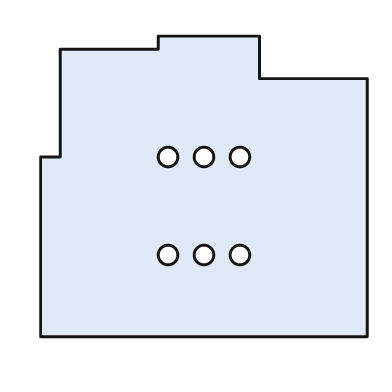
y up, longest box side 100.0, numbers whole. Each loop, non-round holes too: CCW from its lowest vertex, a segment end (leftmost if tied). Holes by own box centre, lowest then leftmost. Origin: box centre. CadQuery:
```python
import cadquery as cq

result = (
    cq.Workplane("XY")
    .moveTo(-50.0, -46.0)
    .lineTo(50.0, -46.0)
    .lineTo(50.0, 33.0)
    .lineTo(17.0, 33.0)
    .lineTo(17.0, 46.0)
    .lineTo(-14.0, 46.0)
    .lineTo(-14.0, 42.0)
    .lineTo(-44.0, 42.0)
    .lineTo(-44.0, 9.0)
    .lineTo(-50.0, 9.0)
    .close()
    .moveTo(-11.0, -21.0)
    .circle(3.0)
    .moveTo(0.0, -21.0)
    .circle(3.0)
    .moveTo(11.0, -21.0)
    .circle(3.0)
    .moveTo(-11.0, 9.0)
    .circle(3.0)
    .moveTo(0.0, 9.0)
    .circle(3.0)
    .moveTo(11.0, 9.0)
    .circle(3.0)
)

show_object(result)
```